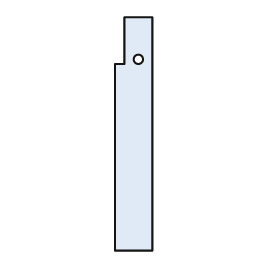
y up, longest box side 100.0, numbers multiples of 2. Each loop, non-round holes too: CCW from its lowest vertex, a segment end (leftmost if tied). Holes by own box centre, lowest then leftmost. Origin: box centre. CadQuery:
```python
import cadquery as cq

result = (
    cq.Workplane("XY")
    .moveTo(-8.0, -50.0)
    .lineTo(8.0, -50.0)
    .lineTo(8.0, 50.0)
    .lineTo(-4.0, 50.0)
    .lineTo(-4.0, 30.0)
    .lineTo(-8.0, 30.0)
    .close()
    .moveTo(2.0, 32.0)
    .circle(2.0)
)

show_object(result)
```